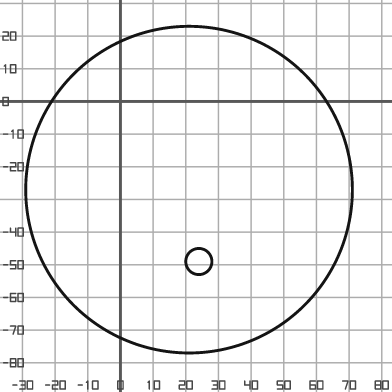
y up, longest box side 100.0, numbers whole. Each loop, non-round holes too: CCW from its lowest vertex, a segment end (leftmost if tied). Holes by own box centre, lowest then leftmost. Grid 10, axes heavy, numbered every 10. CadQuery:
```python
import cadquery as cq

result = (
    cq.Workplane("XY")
    .moveTo(21.0, -27.0)
    .circle(50.0)
    .moveTo(24.0, -49.0)
    .circle(4.0)
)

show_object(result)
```